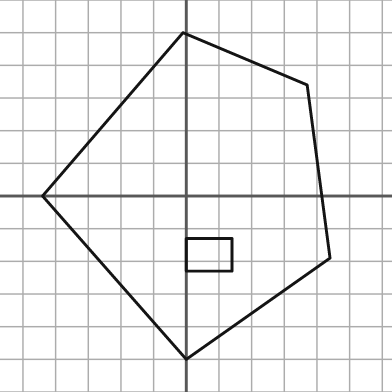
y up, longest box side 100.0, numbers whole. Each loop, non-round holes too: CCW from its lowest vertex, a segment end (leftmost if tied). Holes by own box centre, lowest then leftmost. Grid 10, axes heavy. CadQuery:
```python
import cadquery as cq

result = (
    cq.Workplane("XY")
    .moveTo(0.0, -50.0)
    .lineTo(44.0, -19.0)
    .lineTo(37.0, 34.0)
    .lineTo(-1.0, 50.0)
    .lineTo(-44.0, 0.0)
    .close()
    .moveTo(0.0, -23.0)
    .lineTo(14.0, -23.0)
    .lineTo(14.0, -13.0)
    .lineTo(0.0, -13.0)
    .close()
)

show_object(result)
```